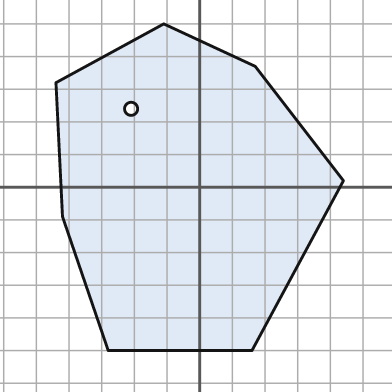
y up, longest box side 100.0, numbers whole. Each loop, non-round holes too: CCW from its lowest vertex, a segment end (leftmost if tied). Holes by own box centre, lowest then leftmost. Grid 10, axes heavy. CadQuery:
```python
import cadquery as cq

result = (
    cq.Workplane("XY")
    .moveTo(-28.0, -50.0)
    .lineTo(16.0, -50.0)
    .lineTo(44.0, 2.0)
    .lineTo(17.0, 37.0)
    .lineTo(-11.0, 50.0)
    .lineTo(-44.0, 32.0)
    .lineTo(-42.0, -9.0)
    .close()
    .moveTo(-21.0, 24.0)
    .circle(2.0)
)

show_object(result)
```